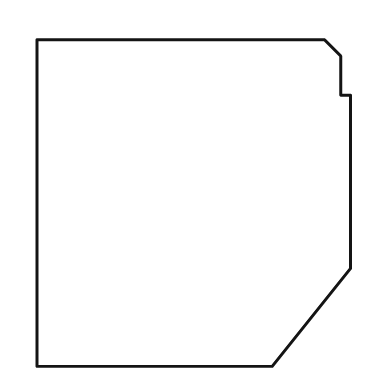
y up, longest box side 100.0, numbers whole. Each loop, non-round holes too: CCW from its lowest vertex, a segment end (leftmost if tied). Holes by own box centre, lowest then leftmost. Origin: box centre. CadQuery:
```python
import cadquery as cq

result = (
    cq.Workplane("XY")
    .moveTo(-48.0, -50.0)
    .lineTo(24.0, -50.0)
    .lineTo(48.0, -20.0)
    .lineTo(48.0, 33.0)
    .lineTo(45.0, 33.0)
    .lineTo(45.0, 45.0)
    .lineTo(40.0, 50.0)
    .lineTo(-48.0, 50.0)
    .close()
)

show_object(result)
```